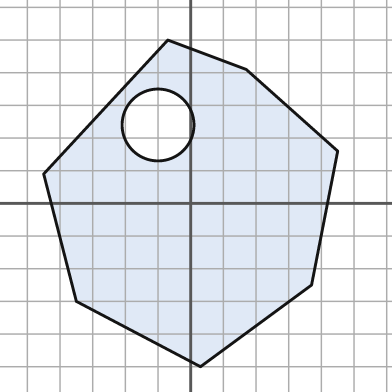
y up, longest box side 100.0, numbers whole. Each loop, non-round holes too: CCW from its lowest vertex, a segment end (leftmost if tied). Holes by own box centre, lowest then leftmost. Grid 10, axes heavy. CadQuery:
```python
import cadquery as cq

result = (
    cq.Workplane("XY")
    .moveTo(3.0, -50.0)
    .lineTo(37.0, -25.0)
    .lineTo(45.0, 16.0)
    .lineTo(17.0, 41.0)
    .lineTo(-7.0, 50.0)
    .lineTo(-45.0, 9.0)
    .lineTo(-35.0, -30.0)
    .close()
    .moveTo(-10.0, 24.0)
    .circle(11.0)
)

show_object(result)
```